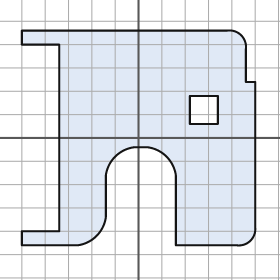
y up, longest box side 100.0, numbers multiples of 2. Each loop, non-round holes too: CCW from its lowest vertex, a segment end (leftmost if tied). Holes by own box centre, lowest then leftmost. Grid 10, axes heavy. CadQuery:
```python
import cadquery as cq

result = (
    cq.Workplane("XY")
    .moveTo(-50.0, -46.0)
    .lineTo(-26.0, -46.0)
    .threePointArc((-18.0, -42.0), (-14.0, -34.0))
    .lineTo(-14.0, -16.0)
    .threePointArc((-10.0, -8.0), (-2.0, -4.0))
    .lineTo(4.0, -4.0)
    .threePointArc((12.0, -8.0), (16.0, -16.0))
    .lineTo(16.0, -46.0)
    .lineTo(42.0, -46.0)
    .threePointArc((48.0, -44.0), (50.0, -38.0))
    .lineTo(50.0, 24.0)
    .lineTo(46.0, 24.0)
    .lineTo(46.0, 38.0)
    .threePointArc((44.0, 44.0), (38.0, 46.0))
    .lineTo(-50.0, 46.0)
    .lineTo(-50.0, 40.0)
    .lineTo(-34.0, 40.0)
    .lineTo(-34.0, -40.0)
    .lineTo(-50.0, -40.0)
    .close()
    .moveTo(22.0, 6.0)
    .lineTo(34.0, 6.0)
    .lineTo(34.0, 18.0)
    .lineTo(22.0, 18.0)
    .close()
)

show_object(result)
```